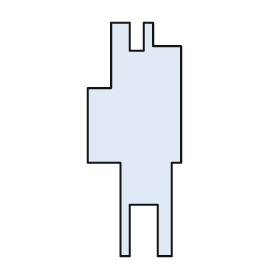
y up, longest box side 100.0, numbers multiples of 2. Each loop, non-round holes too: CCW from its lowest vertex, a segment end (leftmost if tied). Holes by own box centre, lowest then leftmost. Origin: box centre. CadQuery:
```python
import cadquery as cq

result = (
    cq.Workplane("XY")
    .moveTo(-6.0, -50.0)
    .lineTo(-2.0, -50.0)
    .lineTo(-2.0, -28.0)
    .lineTo(10.0, -28.0)
    .lineTo(10.0, -50.0)
    .lineTo(16.0, -50.0)
    .lineTo(16.0, -10.0)
    .lineTo(20.0, -10.0)
    .lineTo(20.0, 40.0)
    .lineTo(8.0, 40.0)
    .lineTo(8.0, 50.0)
    .lineTo(4.0, 50.0)
    .lineTo(4.0, 38.0)
    .lineTo(-2.0, 38.0)
    .lineTo(-2.0, 50.0)
    .lineTo(-10.0, 50.0)
    .lineTo(-10.0, 22.0)
    .lineTo(-20.0, 22.0)
    .lineTo(-20.0, -10.0)
    .lineTo(-6.0, -10.0)
    .close()
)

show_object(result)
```